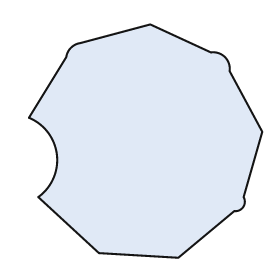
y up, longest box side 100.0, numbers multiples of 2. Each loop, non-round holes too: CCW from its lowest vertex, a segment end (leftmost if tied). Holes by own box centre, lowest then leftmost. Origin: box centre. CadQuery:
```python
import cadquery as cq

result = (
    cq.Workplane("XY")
    .moveTo(14.0, -50.0)
    .lineTo(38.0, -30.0)
    .threePointArc((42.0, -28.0), (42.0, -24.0))
    .lineTo(50.0, 4.0)
    .lineTo(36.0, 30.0)
    .threePointArc((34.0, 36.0), (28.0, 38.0))
    .lineTo(2.0, 50.0)
    .lineTo(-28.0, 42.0)
    .threePointArc((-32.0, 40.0), (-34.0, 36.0))
    .lineTo(-50.0, 10.0)
    .threePointArc((-38.0, -6.0), (-46.0, -24.0))
    .lineTo(-20.0, -48.0)
    .close()
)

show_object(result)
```